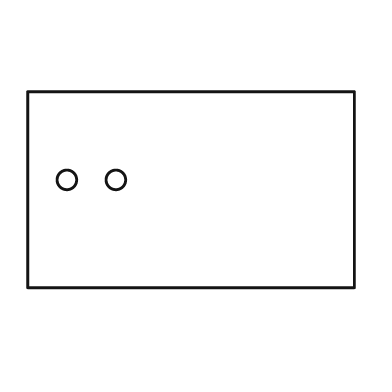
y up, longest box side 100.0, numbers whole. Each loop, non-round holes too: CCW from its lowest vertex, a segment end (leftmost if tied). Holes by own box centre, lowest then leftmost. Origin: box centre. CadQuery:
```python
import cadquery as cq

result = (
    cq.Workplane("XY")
    .moveTo(-50.0, -30.0)
    .lineTo(50.0, -30.0)
    .lineTo(50.0, 30.0)
    .lineTo(-50.0, 30.0)
    .close()
    .moveTo(-38.0, 3.0)
    .circle(3.0)
    .moveTo(-23.0, 3.0)
    .circle(3.0)
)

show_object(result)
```